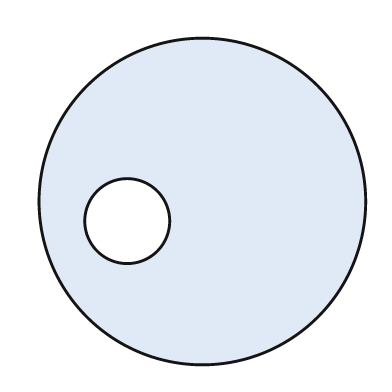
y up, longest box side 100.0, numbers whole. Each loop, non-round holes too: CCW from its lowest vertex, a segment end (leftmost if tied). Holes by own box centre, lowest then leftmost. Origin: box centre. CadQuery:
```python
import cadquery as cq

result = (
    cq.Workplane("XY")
    .moveTo(0.0, 0.0)
    .circle(50.0)
    .moveTo(-23.0, -6.0)
    .circle(13.0)
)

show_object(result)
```